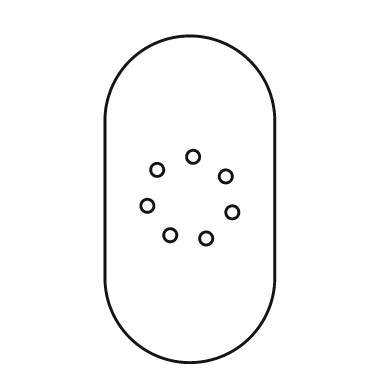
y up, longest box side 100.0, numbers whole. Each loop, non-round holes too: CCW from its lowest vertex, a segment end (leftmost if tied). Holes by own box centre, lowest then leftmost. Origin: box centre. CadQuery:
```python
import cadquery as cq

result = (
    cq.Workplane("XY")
    .moveTo(-26.0, -24.0)
    .threePointArc((0.0, -50.0), (26.0, -24.0))
    .lineTo(26.0, 24.0)
    .threePointArc((0.0, 50.0), (-26.0, 24.0))
    .close()
    .moveTo(5.0, -12.0)
    .circle(2.0)
    .moveTo(-6.0, -11.0)
    .circle(2.0)
    .moveTo(13.0, -4.0)
    .circle(2.0)
    .moveTo(-13.0, -2.0)
    .circle(2.0)
    .moveTo(11.0, 7.0)
    .circle(2.0)
    .moveTo(-10.0, 9.0)
    .circle(2.0)
    .moveTo(1.0, 13.0)
    .circle(2.0)
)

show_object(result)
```